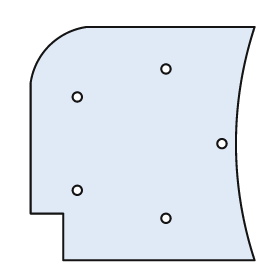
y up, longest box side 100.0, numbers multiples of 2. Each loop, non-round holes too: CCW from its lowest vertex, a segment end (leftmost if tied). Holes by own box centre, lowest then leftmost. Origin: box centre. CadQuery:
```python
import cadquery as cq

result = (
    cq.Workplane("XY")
    .moveTo(-34.0, -50.0)
    .lineTo(48.0, -50.0)
    .threePointArc((40.0, 0.0), (48.0, 50.0))
    .lineTo(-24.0, 50.0)
    .threePointArc((-40.0, 42.0), (-48.0, 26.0))
    .lineTo(-48.0, -30.0)
    .lineTo(-34.0, -30.0)
    .close()
    .moveTo(10.0, -32.0)
    .circle(2.0)
    .moveTo(-28.0, -20.0)
    .circle(2.0)
    .moveTo(34.0, 0.0)
    .circle(2.0)
    .moveTo(-28.0, 20.0)
    .circle(2.0)
    .moveTo(10.0, 32.0)
    .circle(2.0)
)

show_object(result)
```